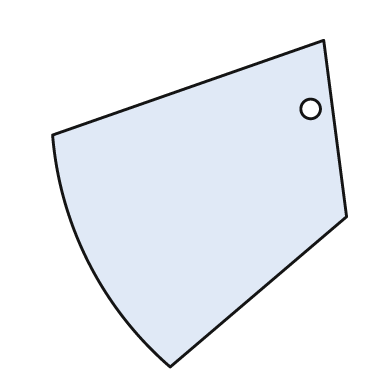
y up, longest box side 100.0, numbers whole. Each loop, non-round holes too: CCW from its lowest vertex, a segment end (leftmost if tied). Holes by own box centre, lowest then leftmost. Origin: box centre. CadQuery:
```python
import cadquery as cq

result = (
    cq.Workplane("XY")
    .moveTo(-9.0, -50.0)
    .lineTo(45.0, -4.0)
    .lineTo(38.0, 50.0)
    .lineTo(-45.0, 21.0)
    .threePointArc((-34.0, -18.0), (-9.0, -50.0))
    .close()
    .moveTo(34.0, 29.0)
    .circle(3.0)
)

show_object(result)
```